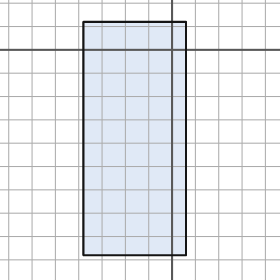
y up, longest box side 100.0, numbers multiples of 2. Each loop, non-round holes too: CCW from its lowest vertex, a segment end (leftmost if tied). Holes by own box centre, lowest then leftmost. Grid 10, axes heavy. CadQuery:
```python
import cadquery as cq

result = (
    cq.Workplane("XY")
    .moveTo(-38.0, -88.0)
    .lineTo(6.0, -88.0)
    .lineTo(6.0, 12.0)
    .lineTo(-38.0, 12.0)
    .close()
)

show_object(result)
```